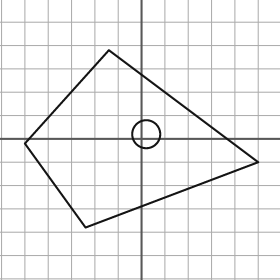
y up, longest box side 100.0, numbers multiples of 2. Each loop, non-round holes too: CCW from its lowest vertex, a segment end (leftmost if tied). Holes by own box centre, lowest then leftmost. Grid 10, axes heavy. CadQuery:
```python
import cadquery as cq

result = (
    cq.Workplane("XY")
    .moveTo(-24.0, -38.0)
    .lineTo(50.0, -10.0)
    .lineTo(-14.0, 38.0)
    .lineTo(-50.0, -2.0)
    .close()
    .moveTo(2.0, 2.0)
    .circle(6.0)
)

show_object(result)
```